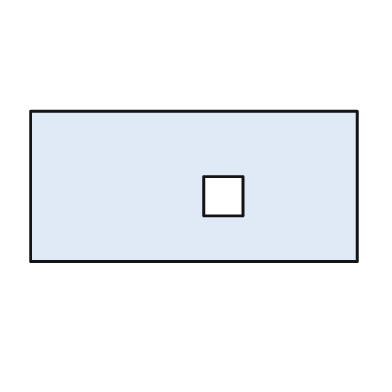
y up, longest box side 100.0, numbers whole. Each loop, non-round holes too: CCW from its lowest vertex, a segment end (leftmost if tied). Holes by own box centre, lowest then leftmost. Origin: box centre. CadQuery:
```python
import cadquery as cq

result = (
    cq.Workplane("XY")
    .moveTo(-50.0, -23.0)
    .lineTo(50.0, -23.0)
    .lineTo(50.0, 23.0)
    .lineTo(-50.0, 23.0)
    .close()
    .moveTo(3.0, -9.0)
    .lineTo(15.0, -9.0)
    .lineTo(15.0, 3.0)
    .lineTo(3.0, 3.0)
    .close()
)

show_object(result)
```